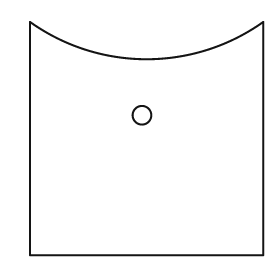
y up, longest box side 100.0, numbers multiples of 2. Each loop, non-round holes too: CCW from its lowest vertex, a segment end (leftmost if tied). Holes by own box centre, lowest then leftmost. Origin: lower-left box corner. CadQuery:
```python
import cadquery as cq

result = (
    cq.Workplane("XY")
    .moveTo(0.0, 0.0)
    .lineTo(100.0, 0.0)
    .lineTo(100.0, 100.0)
    .threePointArc((50.0, 84.0), (0.0, 100.0))
    .close()
    .moveTo(48.0, 60.0)
    .circle(4.0)
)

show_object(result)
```